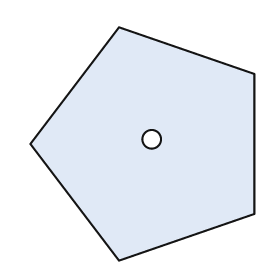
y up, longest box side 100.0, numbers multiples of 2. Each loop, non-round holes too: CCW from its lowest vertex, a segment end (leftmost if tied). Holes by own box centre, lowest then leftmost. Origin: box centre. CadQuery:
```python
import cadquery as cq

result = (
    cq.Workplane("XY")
    .moveTo(-10.0, -50.0)
    .lineTo(48.0, -30.0)
    .lineTo(48.0, 30.0)
    .lineTo(-10.0, 50.0)
    .lineTo(-48.0, 0.0)
    .close()
    .moveTo(4.0, 2.0)
    .circle(4.0)
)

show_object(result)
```